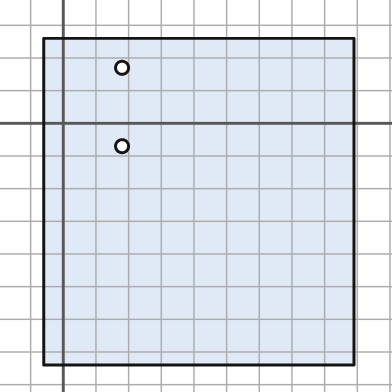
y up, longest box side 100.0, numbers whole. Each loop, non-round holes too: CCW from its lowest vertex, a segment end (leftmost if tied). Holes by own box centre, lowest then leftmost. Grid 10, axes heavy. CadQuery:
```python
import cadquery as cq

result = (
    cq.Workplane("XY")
    .moveTo(-6.0, -74.0)
    .lineTo(89.0, -74.0)
    .lineTo(89.0, 26.0)
    .lineTo(-6.0, 26.0)
    .close()
    .moveTo(18.0, -7.0)
    .circle(2.0)
    .moveTo(18.0, 17.0)
    .circle(2.0)
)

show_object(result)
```